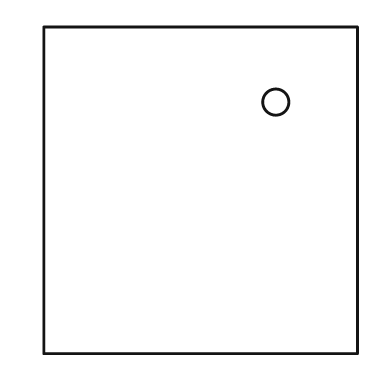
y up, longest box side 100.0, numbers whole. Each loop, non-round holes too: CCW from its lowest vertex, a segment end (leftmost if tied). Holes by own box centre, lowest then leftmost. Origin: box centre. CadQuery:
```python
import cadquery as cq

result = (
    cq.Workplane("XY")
    .moveTo(-48.0, -50.0)
    .lineTo(48.0, -50.0)
    .lineTo(48.0, 50.0)
    .lineTo(-48.0, 50.0)
    .close()
    .moveTo(23.0, 27.0)
    .circle(4.0)
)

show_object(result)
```